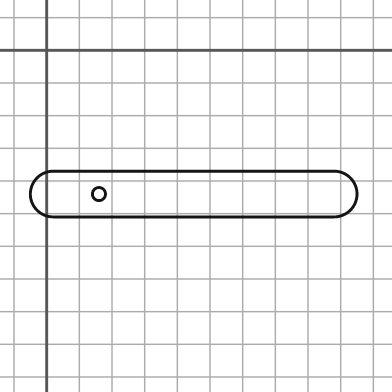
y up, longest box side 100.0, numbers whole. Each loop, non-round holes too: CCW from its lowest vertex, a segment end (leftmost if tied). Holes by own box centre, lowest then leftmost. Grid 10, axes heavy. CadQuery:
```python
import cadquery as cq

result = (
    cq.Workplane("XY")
    .moveTo(2.0, -51.0)
    .lineTo(88.0, -51.0)
    .threePointArc((95.0, -44.0), (88.0, -37.0))
    .lineTo(2.0, -37.0)
    .threePointArc((-5.0, -44.0), (2.0, -51.0))
    .close()
    .moveTo(16.0, -44.0)
    .circle(2.0)
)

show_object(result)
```